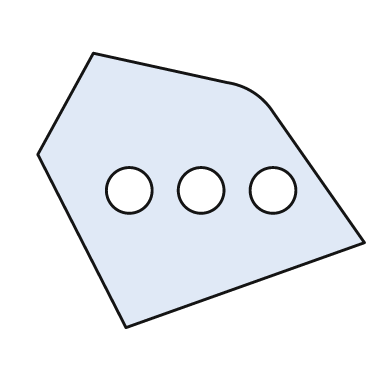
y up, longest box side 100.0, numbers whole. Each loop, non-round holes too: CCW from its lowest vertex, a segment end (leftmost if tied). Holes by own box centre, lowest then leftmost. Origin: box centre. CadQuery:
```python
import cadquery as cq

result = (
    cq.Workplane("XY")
    .moveTo(-23.0, -42.0)
    .lineTo(50.0, -16.0)
    .lineTo(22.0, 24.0)
    .threePointArc((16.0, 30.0), (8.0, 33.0))
    .lineTo(-33.0, 42.0)
    .lineTo(-50.0, 11.0)
    .close()
    .moveTo(-22.0, 0.0)
    .circle(7.0)
    .moveTo(0.0, 0.0)
    .circle(7.0)
    .moveTo(22.0, 0.0)
    .circle(7.0)
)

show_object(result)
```